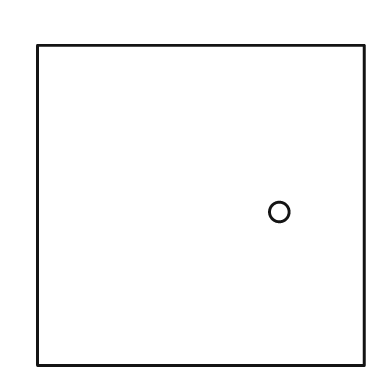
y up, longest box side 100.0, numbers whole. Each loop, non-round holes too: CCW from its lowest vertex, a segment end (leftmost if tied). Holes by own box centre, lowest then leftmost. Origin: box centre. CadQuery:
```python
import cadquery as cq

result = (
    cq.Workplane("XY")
    .moveTo(-50.0, -49.0)
    .lineTo(50.0, -49.0)
    .lineTo(50.0, 49.0)
    .lineTo(-50.0, 49.0)
    .close()
    .moveTo(24.0, -2.0)
    .circle(3.0)
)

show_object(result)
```